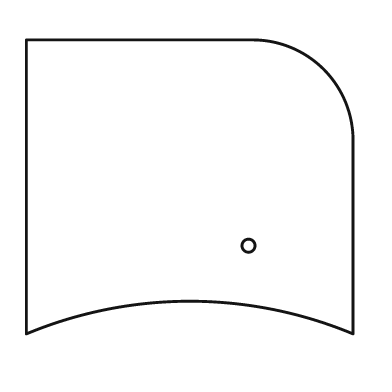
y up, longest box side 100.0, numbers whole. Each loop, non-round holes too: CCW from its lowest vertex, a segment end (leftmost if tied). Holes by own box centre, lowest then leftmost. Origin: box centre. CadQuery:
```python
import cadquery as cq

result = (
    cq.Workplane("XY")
    .moveTo(-50.0, -45.0)
    .threePointArc((0.0, -35.0), (50.0, -45.0))
    .lineTo(50.0, 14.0)
    .threePointArc((41.0, 36.0), (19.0, 45.0))
    .lineTo(-50.0, 45.0)
    .close()
    .moveTo(18.0, -18.0)
    .circle(2.0)
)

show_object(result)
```